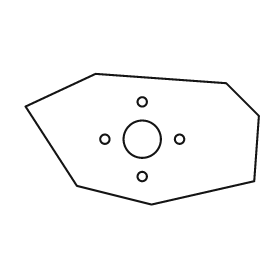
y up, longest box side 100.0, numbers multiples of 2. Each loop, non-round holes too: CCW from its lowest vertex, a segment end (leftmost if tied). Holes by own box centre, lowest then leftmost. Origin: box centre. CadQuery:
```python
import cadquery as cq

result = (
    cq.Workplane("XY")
    .moveTo(4.0, -28.0)
    .lineTo(48.0, -18.0)
    .lineTo(50.0, 10.0)
    .lineTo(36.0, 24.0)
    .lineTo(-20.0, 28.0)
    .lineTo(-50.0, 14.0)
    .lineTo(-28.0, -20.0)
    .close()
    .moveTo(0.0, -16.0)
    .circle(2.0)
    .moveTo(-16.0, 0.0)
    .circle(2.0)
    .moveTo(0.0, 0.0)
    .circle(8.0)
    .moveTo(16.0, 0.0)
    .circle(2.0)
    .moveTo(0.0, 16.0)
    .circle(2.0)
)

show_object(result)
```